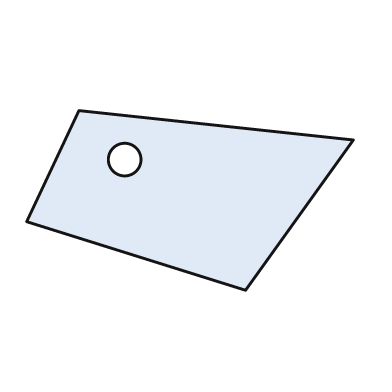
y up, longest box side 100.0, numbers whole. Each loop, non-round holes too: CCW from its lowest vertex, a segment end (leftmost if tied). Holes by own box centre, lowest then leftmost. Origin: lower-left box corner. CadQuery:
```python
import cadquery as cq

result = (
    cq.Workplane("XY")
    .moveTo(67.0, 0.0)
    .lineTo(100.0, 46.0)
    .lineTo(16.0, 55.0)
    .lineTo(0.0, 21.0)
    .close()
    .moveTo(30.0, 40.0)
    .circle(5.0)
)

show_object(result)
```